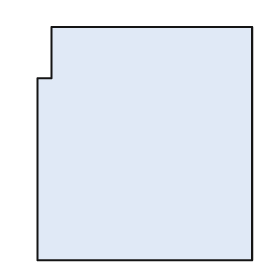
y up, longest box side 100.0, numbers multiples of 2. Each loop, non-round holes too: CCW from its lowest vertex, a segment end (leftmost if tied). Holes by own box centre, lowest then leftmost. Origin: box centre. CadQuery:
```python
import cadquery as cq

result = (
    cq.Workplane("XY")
    .moveTo(-46.0, -50.0)
    .lineTo(46.0, -50.0)
    .lineTo(46.0, 50.0)
    .lineTo(-40.0, 50.0)
    .lineTo(-40.0, 28.0)
    .lineTo(-46.0, 28.0)
    .close()
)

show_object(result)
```